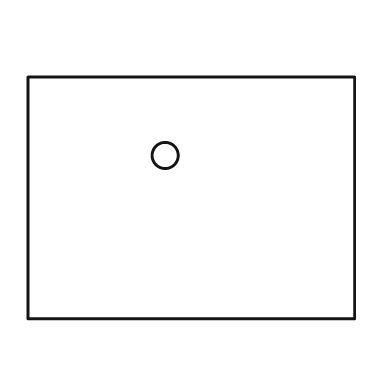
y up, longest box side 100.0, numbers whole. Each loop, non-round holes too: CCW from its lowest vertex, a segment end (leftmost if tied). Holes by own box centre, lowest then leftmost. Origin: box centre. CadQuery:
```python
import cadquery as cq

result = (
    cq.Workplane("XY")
    .moveTo(-50.0, -37.0)
    .lineTo(50.0, -37.0)
    .lineTo(50.0, 37.0)
    .lineTo(-50.0, 37.0)
    .close()
    .moveTo(-8.0, 13.0)
    .circle(4.0)
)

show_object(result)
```